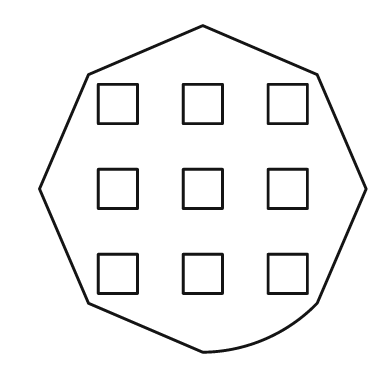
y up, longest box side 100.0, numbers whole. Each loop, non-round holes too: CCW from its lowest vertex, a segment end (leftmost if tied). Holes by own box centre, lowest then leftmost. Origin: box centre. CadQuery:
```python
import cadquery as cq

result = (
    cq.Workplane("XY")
    .moveTo(0.0, -50.0)
    .threePointArc((19.0, -46.0), (35.0, -35.0))
    .lineTo(50.0, 0.0)
    .lineTo(35.0, 35.0)
    .lineTo(0.0, 50.0)
    .lineTo(-35.0, 35.0)
    .lineTo(-50.0, 0.0)
    .lineTo(-35.0, -35.0)
    .close()
    .moveTo(-32.0, -32.0)
    .lineTo(-20.0, -32.0)
    .lineTo(-20.0, -20.0)
    .lineTo(-32.0, -20.0)
    .close()
    .moveTo(-6.0, -32.0)
    .lineTo(6.0, -32.0)
    .lineTo(6.0, -20.0)
    .lineTo(-6.0, -20.0)
    .close()
    .moveTo(20.0, -32.0)
    .lineTo(32.0, -32.0)
    .lineTo(32.0, -20.0)
    .lineTo(20.0, -20.0)
    .close()
    .moveTo(-32.0, -6.0)
    .lineTo(-20.0, -6.0)
    .lineTo(-20.0, 6.0)
    .lineTo(-32.0, 6.0)
    .close()
    .moveTo(-6.0, -6.0)
    .lineTo(6.0, -6.0)
    .lineTo(6.0, 6.0)
    .lineTo(-6.0, 6.0)
    .close()
    .moveTo(20.0, -6.0)
    .lineTo(32.0, -6.0)
    .lineTo(32.0, 6.0)
    .lineTo(20.0, 6.0)
    .close()
    .moveTo(-32.0, 20.0)
    .lineTo(-20.0, 20.0)
    .lineTo(-20.0, 32.0)
    .lineTo(-32.0, 32.0)
    .close()
    .moveTo(-6.0, 20.0)
    .lineTo(6.0, 20.0)
    .lineTo(6.0, 32.0)
    .lineTo(-6.0, 32.0)
    .close()
    .moveTo(20.0, 20.0)
    .lineTo(32.0, 20.0)
    .lineTo(32.0, 32.0)
    .lineTo(20.0, 32.0)
    .close()
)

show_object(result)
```